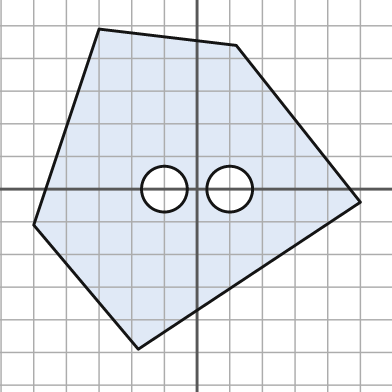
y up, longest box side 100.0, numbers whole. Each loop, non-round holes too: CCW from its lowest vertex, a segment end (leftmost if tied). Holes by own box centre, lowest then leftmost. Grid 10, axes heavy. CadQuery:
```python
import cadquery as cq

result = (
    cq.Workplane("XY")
    .moveTo(-18.0, -49.0)
    .lineTo(50.0, -4.0)
    .lineTo(12.0, 44.0)
    .lineTo(-30.0, 49.0)
    .lineTo(-50.0, -11.0)
    .close()
    .moveTo(-10.0, 0.0)
    .circle(7.0)
    .moveTo(10.0, 0.0)
    .circle(7.0)
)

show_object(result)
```